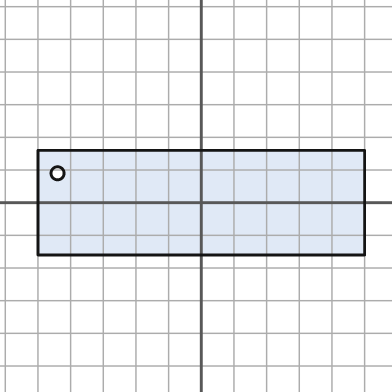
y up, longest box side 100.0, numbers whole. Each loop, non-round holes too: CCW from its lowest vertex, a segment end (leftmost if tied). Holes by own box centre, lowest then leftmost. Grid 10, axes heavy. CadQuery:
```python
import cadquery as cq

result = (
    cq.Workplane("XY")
    .moveTo(-50.0, -16.0)
    .lineTo(50.0, -16.0)
    .lineTo(50.0, 16.0)
    .lineTo(-50.0, 16.0)
    .close()
    .moveTo(-44.0, 9.0)
    .circle(2.0)
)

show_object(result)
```